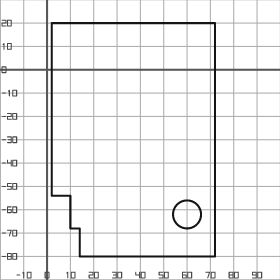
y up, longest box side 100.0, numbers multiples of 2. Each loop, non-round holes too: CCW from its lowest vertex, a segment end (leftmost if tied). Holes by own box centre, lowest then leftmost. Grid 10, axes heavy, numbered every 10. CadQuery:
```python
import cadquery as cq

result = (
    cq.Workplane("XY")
    .moveTo(14.0, -80.0)
    .lineTo(72.0, -80.0)
    .lineTo(72.0, 20.0)
    .lineTo(2.0, 20.0)
    .lineTo(2.0, -54.0)
    .lineTo(10.0, -54.0)
    .lineTo(10.0, -68.0)
    .lineTo(14.0, -68.0)
    .close()
    .moveTo(60.0, -62.0)
    .circle(6.0)
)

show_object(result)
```